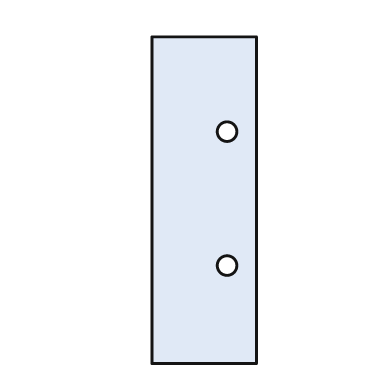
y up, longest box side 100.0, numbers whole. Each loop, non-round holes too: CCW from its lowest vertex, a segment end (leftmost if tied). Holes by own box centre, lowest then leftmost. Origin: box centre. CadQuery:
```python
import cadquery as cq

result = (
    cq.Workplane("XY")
    .moveTo(-16.0, -50.0)
    .lineTo(16.0, -50.0)
    .lineTo(16.0, 50.0)
    .lineTo(-16.0, 50.0)
    .close()
    .moveTo(7.0, -20.0)
    .circle(3.0)
    .moveTo(7.0, 21.0)
    .circle(3.0)
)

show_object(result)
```